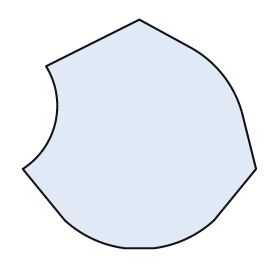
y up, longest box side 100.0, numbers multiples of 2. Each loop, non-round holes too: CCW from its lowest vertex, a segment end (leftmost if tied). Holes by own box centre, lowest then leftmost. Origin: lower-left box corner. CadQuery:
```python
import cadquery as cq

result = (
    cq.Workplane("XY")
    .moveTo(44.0, 0.0)
    .lineTo(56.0, 0.0)
    .threePointArc((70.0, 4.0), (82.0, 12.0))
    .lineTo(100.0, 34.0)
    .lineTo(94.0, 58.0)
    .threePointArc((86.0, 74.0), (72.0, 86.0))
    .lineTo(50.0, 98.0)
    .lineTo(10.0, 78.0)
    .threePointArc((14.0, 54.0), (0.0, 34.0))
    .lineTo(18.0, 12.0)
    .threePointArc((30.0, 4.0), (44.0, 0.0))
    .close()
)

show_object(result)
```